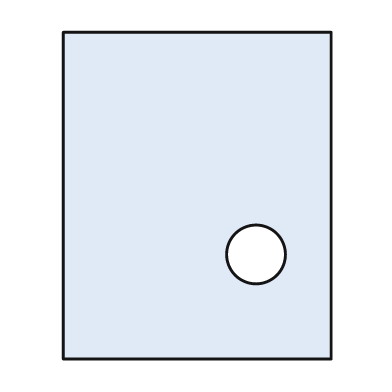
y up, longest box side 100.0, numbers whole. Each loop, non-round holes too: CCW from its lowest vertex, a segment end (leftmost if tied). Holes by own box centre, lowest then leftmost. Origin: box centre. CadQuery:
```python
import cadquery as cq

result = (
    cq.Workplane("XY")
    .moveTo(-41.0, -50.0)
    .lineTo(41.0, -50.0)
    .lineTo(41.0, 50.0)
    .lineTo(-41.0, 50.0)
    .close()
    .moveTo(18.0, -18.0)
    .circle(9.0)
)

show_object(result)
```